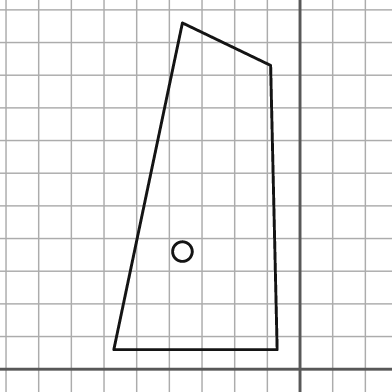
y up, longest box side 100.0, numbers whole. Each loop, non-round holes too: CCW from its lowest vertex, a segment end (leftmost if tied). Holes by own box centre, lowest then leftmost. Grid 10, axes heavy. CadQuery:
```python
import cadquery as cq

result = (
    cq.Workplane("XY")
    .moveTo(-57.0, 6.0)
    .lineTo(-7.0, 6.0)
    .lineTo(-9.0, 93.0)
    .lineTo(-36.0, 106.0)
    .close()
    .moveTo(-36.0, 36.0)
    .circle(3.0)
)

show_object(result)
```